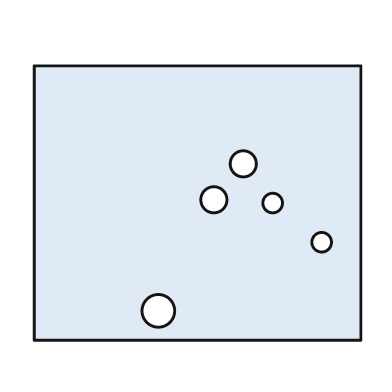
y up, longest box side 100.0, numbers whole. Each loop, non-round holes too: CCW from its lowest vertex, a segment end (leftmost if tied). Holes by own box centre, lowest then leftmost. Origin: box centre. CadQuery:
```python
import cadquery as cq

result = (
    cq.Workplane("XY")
    .moveTo(-50.0, -42.0)
    .lineTo(50.0, -42.0)
    .lineTo(50.0, 42.0)
    .lineTo(-50.0, 42.0)
    .close()
    .moveTo(-12.0, -33.0)
    .circle(5.0)
    .moveTo(38.0, -12.0)
    .circle(3.0)
    .moveTo(23.0, 0.0)
    .circle(3.0)
    .moveTo(5.0, 1.0)
    .circle(4.0)
    .moveTo(14.0, 12.0)
    .circle(4.0)
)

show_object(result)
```